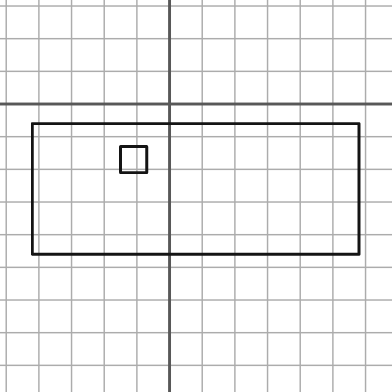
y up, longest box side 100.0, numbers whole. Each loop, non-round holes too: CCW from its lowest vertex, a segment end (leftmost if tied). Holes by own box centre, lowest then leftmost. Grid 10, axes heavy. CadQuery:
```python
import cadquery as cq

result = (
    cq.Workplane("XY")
    .moveTo(-42.0, -46.0)
    .lineTo(58.0, -46.0)
    .lineTo(58.0, -6.0)
    .lineTo(-42.0, -6.0)
    .close()
    .moveTo(-15.0, -21.0)
    .lineTo(-7.0, -21.0)
    .lineTo(-7.0, -13.0)
    .lineTo(-15.0, -13.0)
    .close()
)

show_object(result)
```